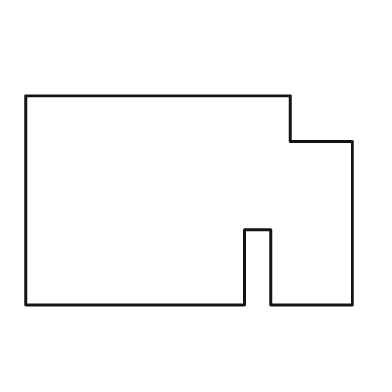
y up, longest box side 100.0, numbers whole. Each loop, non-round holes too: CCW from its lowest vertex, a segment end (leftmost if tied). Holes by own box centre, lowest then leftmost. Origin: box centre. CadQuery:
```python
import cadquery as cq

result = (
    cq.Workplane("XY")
    .moveTo(-50.0, -32.0)
    .lineTo(17.0, -32.0)
    .lineTo(17.0, -9.0)
    .lineTo(25.0, -9.0)
    .lineTo(25.0, -32.0)
    .lineTo(50.0, -32.0)
    .lineTo(50.0, 18.0)
    .lineTo(31.0, 18.0)
    .lineTo(31.0, 32.0)
    .lineTo(-50.0, 32.0)
    .close()
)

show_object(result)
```